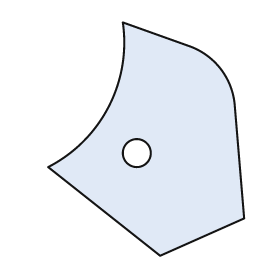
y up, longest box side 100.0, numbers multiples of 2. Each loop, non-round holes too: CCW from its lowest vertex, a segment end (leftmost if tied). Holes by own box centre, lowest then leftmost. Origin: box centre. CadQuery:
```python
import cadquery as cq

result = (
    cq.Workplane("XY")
    .moveTo(6.0, -50.0)
    .lineTo(42.0, -34.0)
    .lineTo(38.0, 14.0)
    .threePointArc((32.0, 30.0), (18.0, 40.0))
    .lineTo(-10.0, 50.0)
    .threePointArc((-16.0, 14.0), (-42.0, -12.0))
    .close()
    .moveTo(-4.0, -6.0)
    .circle(6.0)
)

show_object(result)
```